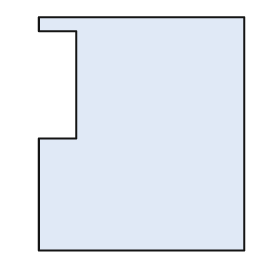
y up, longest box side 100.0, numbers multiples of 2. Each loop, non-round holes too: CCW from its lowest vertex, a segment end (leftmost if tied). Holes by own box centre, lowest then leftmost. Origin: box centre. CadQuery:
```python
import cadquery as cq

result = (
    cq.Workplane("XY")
    .moveTo(-44.0, -50.0)
    .lineTo(44.0, -50.0)
    .lineTo(44.0, 50.0)
    .lineTo(-44.0, 50.0)
    .lineTo(-44.0, 44.0)
    .lineTo(-28.0, 44.0)
    .lineTo(-28.0, -2.0)
    .lineTo(-44.0, -2.0)
    .close()
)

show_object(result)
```